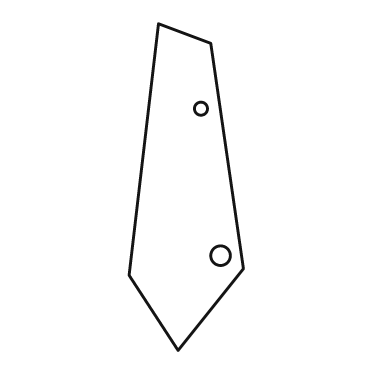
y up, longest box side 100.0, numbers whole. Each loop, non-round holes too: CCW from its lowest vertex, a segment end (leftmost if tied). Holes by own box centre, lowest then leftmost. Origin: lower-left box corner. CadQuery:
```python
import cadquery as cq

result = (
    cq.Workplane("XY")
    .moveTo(15.0, 0.0)
    .lineTo(35.0, 25.0)
    .lineTo(25.0, 94.0)
    .lineTo(9.0, 100.0)
    .lineTo(0.0, 23.0)
    .close()
    .moveTo(28.0, 29.0)
    .circle(3.0)
    .moveTo(22.0, 74.0)
    .circle(2.0)
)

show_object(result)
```